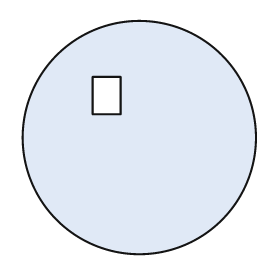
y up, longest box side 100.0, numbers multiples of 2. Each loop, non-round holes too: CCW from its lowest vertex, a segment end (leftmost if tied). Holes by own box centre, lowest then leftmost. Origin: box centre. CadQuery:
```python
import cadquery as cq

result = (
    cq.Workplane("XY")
    .moveTo(0.0, 0.0)
    .circle(50.0)
    .moveTo(-20.0, 10.0)
    .lineTo(-8.0, 10.0)
    .lineTo(-8.0, 26.0)
    .lineTo(-20.0, 26.0)
    .close()
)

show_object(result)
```